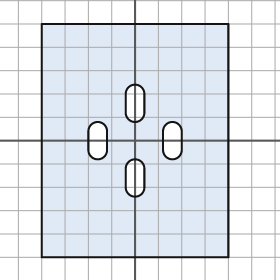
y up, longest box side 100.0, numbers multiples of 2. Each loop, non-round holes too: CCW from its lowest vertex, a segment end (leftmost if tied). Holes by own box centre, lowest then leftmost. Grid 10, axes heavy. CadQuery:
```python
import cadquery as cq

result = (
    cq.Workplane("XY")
    .moveTo(-40.0, -50.0)
    .lineTo(40.0, -50.0)
    .lineTo(40.0, 50.0)
    .lineTo(-40.0, 50.0)
    .close()
    .moveTo(-4.0, -20.0)
    .threePointArc((0.0, -24.0), (4.0, -20.0))
    .lineTo(4.0, -12.0)
    .threePointArc((0.0, -8.0), (-4.0, -12.0))
    .close()
    .moveTo(-20.0, -4.0)
    .threePointArc((-16.0, -8.0), (-12.0, -4.0))
    .lineTo(-12.0, 4.0)
    .threePointArc((-16.0, 8.0), (-20.0, 4.0))
    .close()
    .moveTo(12.0, -4.0)
    .threePointArc((16.0, -8.0), (20.0, -4.0))
    .lineTo(20.0, 4.0)
    .threePointArc((16.0, 8.0), (12.0, 4.0))
    .close()
    .moveTo(-4.0, 12.0)
    .threePointArc((0.0, 8.0), (4.0, 12.0))
    .lineTo(4.0, 20.0)
    .threePointArc((0.0, 24.0), (-4.0, 20.0))
    .close()
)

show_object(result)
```